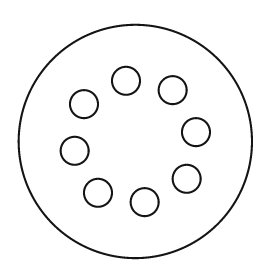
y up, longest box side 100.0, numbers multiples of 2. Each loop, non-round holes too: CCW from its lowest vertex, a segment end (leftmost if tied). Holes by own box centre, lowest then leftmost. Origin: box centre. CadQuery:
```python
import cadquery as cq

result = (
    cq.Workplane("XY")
    .moveTo(0.0, 0.0)
    .circle(50.0)
    .moveTo(4.0, -26.0)
    .circle(6.0)
    .moveTo(-16.0, -22.0)
    .circle(6.0)
    .moveTo(22.0, -16.0)
    .circle(6.0)
    .moveTo(-26.0, -4.0)
    .circle(6.0)
    .moveTo(26.0, 4.0)
    .circle(6.0)
    .moveTo(-22.0, 16.0)
    .circle(6.0)
    .moveTo(16.0, 22.0)
    .circle(6.0)
    .moveTo(-4.0, 26.0)
    .circle(6.0)
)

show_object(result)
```